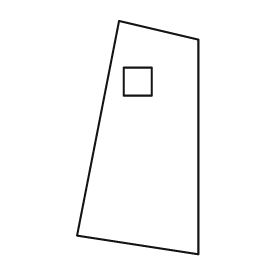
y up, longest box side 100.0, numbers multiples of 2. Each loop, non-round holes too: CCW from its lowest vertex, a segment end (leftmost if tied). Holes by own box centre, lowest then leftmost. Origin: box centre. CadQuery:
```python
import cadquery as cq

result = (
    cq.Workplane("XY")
    .moveTo(26.0, -50.0)
    .lineTo(26.0, 42.0)
    .lineTo(-8.0, 50.0)
    .lineTo(-26.0, -42.0)
    .close()
    .moveTo(-6.0, 18.0)
    .lineTo(6.0, 18.0)
    .lineTo(6.0, 30.0)
    .lineTo(-6.0, 30.0)
    .close()
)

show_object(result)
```